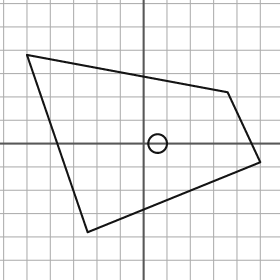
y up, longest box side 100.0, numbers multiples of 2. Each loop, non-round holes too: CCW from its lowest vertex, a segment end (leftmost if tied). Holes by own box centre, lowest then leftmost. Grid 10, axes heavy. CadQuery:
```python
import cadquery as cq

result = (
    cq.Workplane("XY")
    .moveTo(-24.0, -38.0)
    .lineTo(50.0, -8.0)
    .lineTo(36.0, 22.0)
    .lineTo(-50.0, 38.0)
    .close()
    .moveTo(6.0, 0.0)
    .circle(4.0)
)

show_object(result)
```